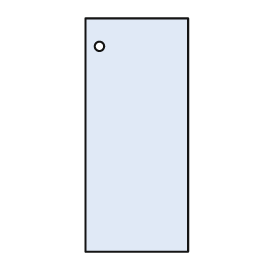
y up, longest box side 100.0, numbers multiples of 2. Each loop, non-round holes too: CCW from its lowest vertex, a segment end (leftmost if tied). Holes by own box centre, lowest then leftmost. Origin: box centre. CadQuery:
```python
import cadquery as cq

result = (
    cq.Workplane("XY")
    .moveTo(-22.0, -50.0)
    .lineTo(22.0, -50.0)
    .lineTo(22.0, 50.0)
    .lineTo(-22.0, 50.0)
    .close()
    .moveTo(-16.0, 38.0)
    .circle(2.0)
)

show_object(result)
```